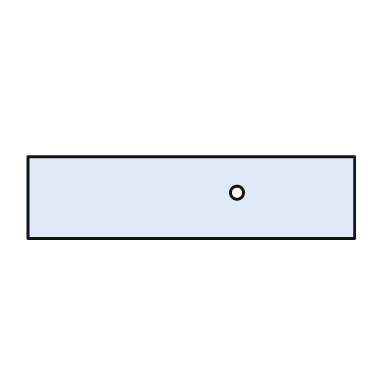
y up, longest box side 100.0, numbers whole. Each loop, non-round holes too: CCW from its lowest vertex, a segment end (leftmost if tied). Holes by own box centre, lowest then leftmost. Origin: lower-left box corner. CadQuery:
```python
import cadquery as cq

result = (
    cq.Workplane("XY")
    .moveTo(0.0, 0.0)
    .lineTo(100.0, 0.0)
    .lineTo(100.0, 25.0)
    .lineTo(0.0, 25.0)
    .close()
    .moveTo(64.0, 14.0)
    .circle(2.0)
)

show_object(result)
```